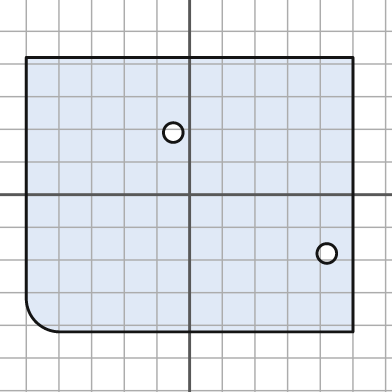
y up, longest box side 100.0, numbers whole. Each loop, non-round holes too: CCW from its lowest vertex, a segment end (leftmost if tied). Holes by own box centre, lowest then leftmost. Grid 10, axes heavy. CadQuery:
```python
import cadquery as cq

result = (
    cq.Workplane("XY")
    .moveTo(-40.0, -42.0)
    .lineTo(50.0, -42.0)
    .lineTo(50.0, 42.0)
    .lineTo(-50.0, 42.0)
    .lineTo(-50.0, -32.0)
    .threePointArc((-47.0, -39.0), (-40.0, -42.0))
    .close()
    .moveTo(42.0, -18.0)
    .circle(3.0)
    .moveTo(-5.0, 19.0)
    .circle(3.0)
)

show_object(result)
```